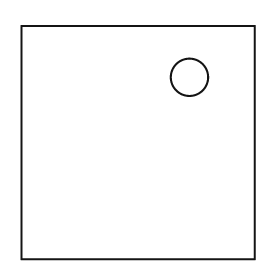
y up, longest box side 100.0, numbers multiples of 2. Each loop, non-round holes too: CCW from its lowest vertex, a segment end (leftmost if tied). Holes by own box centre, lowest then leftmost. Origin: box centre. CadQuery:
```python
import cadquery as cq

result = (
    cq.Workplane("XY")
    .moveTo(-50.0, -50.0)
    .lineTo(50.0, -50.0)
    .lineTo(50.0, 50.0)
    .lineTo(-50.0, 50.0)
    .close()
    .moveTo(22.0, 28.0)
    .circle(8.0)
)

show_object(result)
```